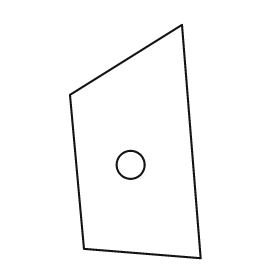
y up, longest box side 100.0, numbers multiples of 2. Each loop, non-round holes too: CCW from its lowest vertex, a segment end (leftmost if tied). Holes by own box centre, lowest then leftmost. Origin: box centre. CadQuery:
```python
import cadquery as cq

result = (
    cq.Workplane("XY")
    .moveTo(28.0, -50.0)
    .lineTo(20.0, 50.0)
    .lineTo(-28.0, 20.0)
    .lineTo(-22.0, -46.0)
    .close()
    .moveTo(-2.0, -10.0)
    .circle(6.0)
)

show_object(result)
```